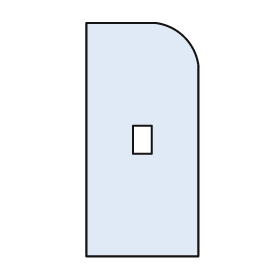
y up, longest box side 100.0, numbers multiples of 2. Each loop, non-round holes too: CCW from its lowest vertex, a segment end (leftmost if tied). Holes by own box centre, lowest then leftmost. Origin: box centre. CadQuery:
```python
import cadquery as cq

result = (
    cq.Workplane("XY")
    .moveTo(-24.0, -50.0)
    .lineTo(24.0, -50.0)
    .lineTo(24.0, 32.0)
    .threePointArc((18.0, 44.0), (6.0, 50.0))
    .lineTo(-24.0, 50.0)
    .close()
    .moveTo(-4.0, -6.0)
    .lineTo(4.0, -6.0)
    .lineTo(4.0, 6.0)
    .lineTo(-4.0, 6.0)
    .close()
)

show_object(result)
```